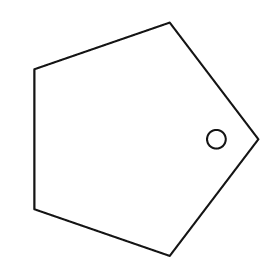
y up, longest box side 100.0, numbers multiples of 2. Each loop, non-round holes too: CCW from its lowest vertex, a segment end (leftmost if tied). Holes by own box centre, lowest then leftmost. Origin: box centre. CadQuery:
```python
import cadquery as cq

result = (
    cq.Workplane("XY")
    .moveTo(10.0, -50.0)
    .lineTo(48.0, 0.0)
    .lineTo(10.0, 50.0)
    .lineTo(-48.0, 30.0)
    .lineTo(-48.0, -30.0)
    .close()
    .moveTo(30.0, 0.0)
    .circle(4.0)
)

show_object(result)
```